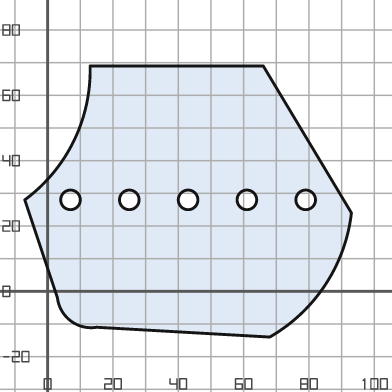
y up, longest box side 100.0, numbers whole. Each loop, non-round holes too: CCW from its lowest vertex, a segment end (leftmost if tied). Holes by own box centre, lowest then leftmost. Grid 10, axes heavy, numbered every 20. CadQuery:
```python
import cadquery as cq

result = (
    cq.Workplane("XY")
    .moveTo(68.0, -14.0)
    .threePointArc((85.0, 2.0), (93.0, 24.0))
    .lineTo(66.0, 69.0)
    .lineTo(13.0, 69.0)
    .threePointArc((8.0, 46.0), (-7.0, 28.0))
    .lineTo(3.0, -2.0)
    .threePointArc((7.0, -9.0), (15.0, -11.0))
    .close()
    .moveTo(7.0, 28.0)
    .circle(3.0)
    .moveTo(25.0, 28.0)
    .circle(3.0)
    .moveTo(43.0, 28.0)
    .circle(3.0)
    .moveTo(61.0, 28.0)
    .circle(3.0)
    .moveTo(79.0, 28.0)
    .circle(3.0)
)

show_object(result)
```